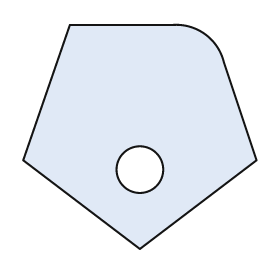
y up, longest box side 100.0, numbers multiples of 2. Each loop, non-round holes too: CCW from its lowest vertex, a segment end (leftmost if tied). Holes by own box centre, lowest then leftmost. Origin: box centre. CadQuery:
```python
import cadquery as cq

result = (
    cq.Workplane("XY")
    .moveTo(0.0, -48.0)
    .lineTo(50.0, -10.0)
    .lineTo(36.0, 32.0)
    .threePointArc((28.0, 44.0), (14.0, 48.0))
    .lineTo(-30.0, 48.0)
    .lineTo(-50.0, -10.0)
    .close()
    .moveTo(0.0, -14.0)
    .circle(10.0)
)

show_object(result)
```